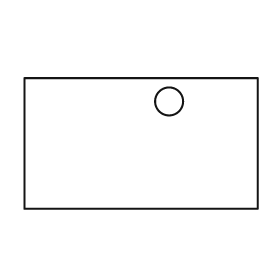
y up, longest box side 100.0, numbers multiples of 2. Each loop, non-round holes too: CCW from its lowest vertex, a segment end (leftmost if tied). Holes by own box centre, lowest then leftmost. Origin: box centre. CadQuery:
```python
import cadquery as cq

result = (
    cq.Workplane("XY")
    .moveTo(-50.0, -28.0)
    .lineTo(50.0, -28.0)
    .lineTo(50.0, 28.0)
    .lineTo(-50.0, 28.0)
    .close()
    .moveTo(12.0, 18.0)
    .circle(6.0)
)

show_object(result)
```